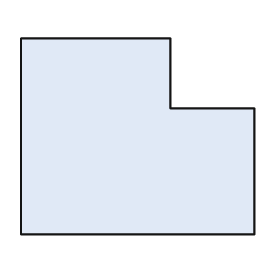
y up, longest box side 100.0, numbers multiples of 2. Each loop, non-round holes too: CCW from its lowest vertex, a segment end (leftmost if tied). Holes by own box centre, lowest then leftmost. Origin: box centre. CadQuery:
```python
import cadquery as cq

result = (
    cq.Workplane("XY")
    .moveTo(-50.0, -42.0)
    .lineTo(50.0, -42.0)
    .lineTo(50.0, 12.0)
    .lineTo(14.0, 12.0)
    .lineTo(14.0, 42.0)
    .lineTo(-50.0, 42.0)
    .close()
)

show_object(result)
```